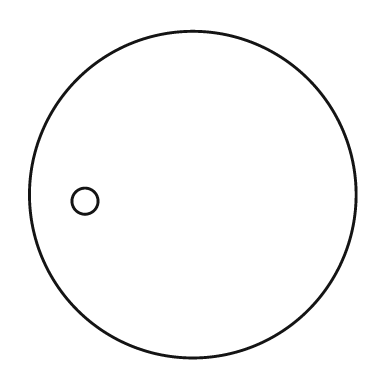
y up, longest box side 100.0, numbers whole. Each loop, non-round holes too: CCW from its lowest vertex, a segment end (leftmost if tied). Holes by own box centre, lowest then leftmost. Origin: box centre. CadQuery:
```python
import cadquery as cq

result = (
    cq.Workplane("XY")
    .moveTo(0.0, 0.0)
    .circle(50.0)
    .moveTo(-33.0, -2.0)
    .circle(4.0)
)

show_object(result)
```